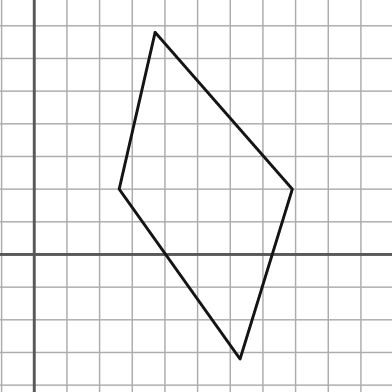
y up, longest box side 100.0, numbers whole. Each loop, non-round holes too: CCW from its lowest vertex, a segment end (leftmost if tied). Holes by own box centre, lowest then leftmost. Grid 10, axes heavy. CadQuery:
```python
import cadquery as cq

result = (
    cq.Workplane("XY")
    .moveTo(63.0, -32.0)
    .lineTo(79.0, 20.0)
    .lineTo(37.0, 68.0)
    .lineTo(26.0, 20.0)
    .close()
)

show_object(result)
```